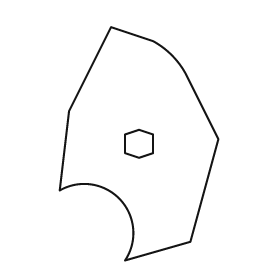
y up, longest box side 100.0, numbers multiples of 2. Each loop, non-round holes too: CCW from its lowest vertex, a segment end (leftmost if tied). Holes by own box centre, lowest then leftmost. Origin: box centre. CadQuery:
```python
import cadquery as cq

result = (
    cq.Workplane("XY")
    .moveTo(-6.0, -50.0)
    .lineTo(22.0, -42.0)
    .lineTo(34.0, 2.0)
    .lineTo(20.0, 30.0)
    .threePointArc((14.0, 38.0), (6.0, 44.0))
    .lineTo(-12.0, 50.0)
    .lineTo(-30.0, 14.0)
    .lineTo(-34.0, -20.0)
    .threePointArc((-8.0, -24.0), (-6.0, -50.0))
    .close()
    .moveTo(0.0, -6.0)
    .lineTo(6.0, -4.0)
    .lineTo(6.0, 4.0)
    .lineTo(0.0, 6.0)
    .lineTo(-6.0, 4.0)
    .lineTo(-6.0, -4.0)
    .close()
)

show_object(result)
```